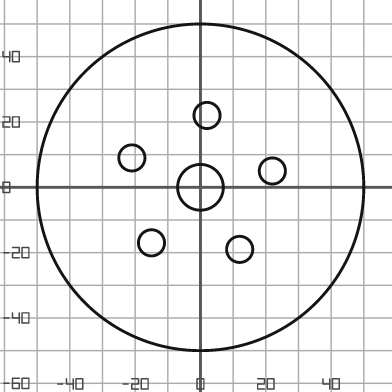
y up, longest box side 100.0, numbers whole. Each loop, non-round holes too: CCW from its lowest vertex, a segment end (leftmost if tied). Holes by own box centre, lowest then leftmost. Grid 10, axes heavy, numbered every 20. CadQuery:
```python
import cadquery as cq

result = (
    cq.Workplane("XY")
    .moveTo(0.0, 0.0)
    .circle(50.0)
    .moveTo(12.0, -19.0)
    .circle(4.0)
    .moveTo(-15.0, -17.0)
    .circle(4.0)
    .moveTo(0.0, 0.0)
    .circle(7.0)
    .moveTo(22.0, 5.0)
    .circle(4.0)
    .moveTo(-21.0, 9.0)
    .circle(4.0)
    .moveTo(2.0, 22.0)
    .circle(4.0)
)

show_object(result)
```